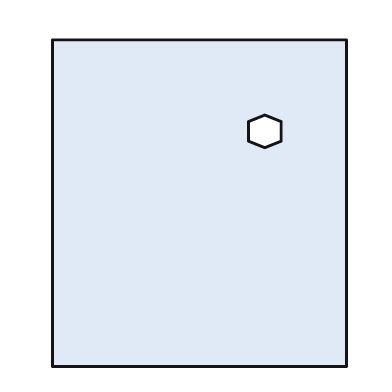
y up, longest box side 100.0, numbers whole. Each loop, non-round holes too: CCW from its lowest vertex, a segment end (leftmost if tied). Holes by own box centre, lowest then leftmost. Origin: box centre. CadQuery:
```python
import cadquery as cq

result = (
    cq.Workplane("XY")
    .moveTo(-45.0, -50.0)
    .lineTo(45.0, -50.0)
    .lineTo(45.0, 50.0)
    .lineTo(-45.0, 50.0)
    .close()
    .moveTo(20.0, 17.0)
    .lineTo(25.0, 19.0)
    .lineTo(25.0, 25.0)
    .lineTo(20.0, 27.0)
    .lineTo(15.0, 25.0)
    .lineTo(15.0, 19.0)
    .close()
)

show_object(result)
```